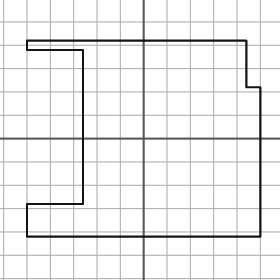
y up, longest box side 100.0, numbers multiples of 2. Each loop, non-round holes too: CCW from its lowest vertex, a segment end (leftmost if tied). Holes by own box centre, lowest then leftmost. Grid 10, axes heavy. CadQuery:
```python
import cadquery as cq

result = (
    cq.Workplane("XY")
    .moveTo(-50.0, -42.0)
    .lineTo(50.0, -42.0)
    .lineTo(50.0, 22.0)
    .lineTo(44.0, 22.0)
    .lineTo(44.0, 42.0)
    .lineTo(-50.0, 42.0)
    .lineTo(-50.0, 38.0)
    .lineTo(-26.0, 38.0)
    .lineTo(-26.0, -28.0)
    .lineTo(-50.0, -28.0)
    .close()
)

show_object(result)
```